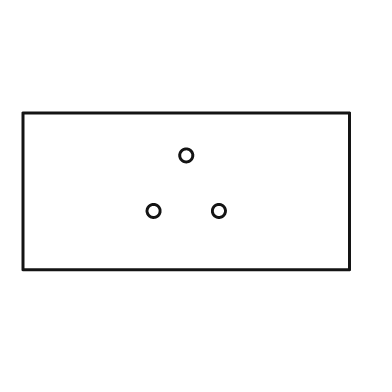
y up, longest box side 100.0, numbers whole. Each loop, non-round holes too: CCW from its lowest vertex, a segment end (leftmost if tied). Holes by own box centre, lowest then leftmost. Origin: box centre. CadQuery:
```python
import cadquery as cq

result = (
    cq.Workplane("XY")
    .moveTo(-50.0, -24.0)
    .lineTo(50.0, -24.0)
    .lineTo(50.0, 24.0)
    .lineTo(-50.0, 24.0)
    .close()
    .moveTo(-10.0, -6.0)
    .circle(2.0)
    .moveTo(10.0, -6.0)
    .circle(2.0)
    .moveTo(0.0, 11.0)
    .circle(2.0)
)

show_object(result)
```